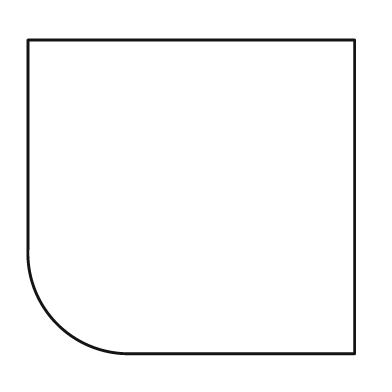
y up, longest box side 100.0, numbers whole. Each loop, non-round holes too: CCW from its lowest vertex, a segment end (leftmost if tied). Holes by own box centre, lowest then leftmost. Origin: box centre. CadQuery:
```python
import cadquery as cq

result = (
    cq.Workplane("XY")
    .moveTo(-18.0, -48.0)
    .lineTo(50.0, -48.0)
    .lineTo(50.0, 48.0)
    .lineTo(-50.0, 48.0)
    .lineTo(-50.0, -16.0)
    .threePointArc((-41.0, -39.0), (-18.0, -48.0))
    .close()
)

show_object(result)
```